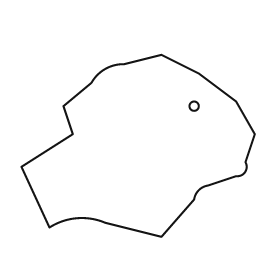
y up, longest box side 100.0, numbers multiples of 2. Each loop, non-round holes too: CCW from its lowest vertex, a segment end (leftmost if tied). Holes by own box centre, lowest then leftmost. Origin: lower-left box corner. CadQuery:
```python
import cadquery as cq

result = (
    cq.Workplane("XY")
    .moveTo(60.0, 0.0)
    .lineTo(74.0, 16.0)
    .threePointArc((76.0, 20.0), (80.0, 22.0))
    .lineTo(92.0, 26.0)
    .threePointArc((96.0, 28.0), (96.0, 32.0))
    .lineTo(100.0, 44.0)
    .lineTo(92.0, 58.0)
    .lineTo(76.0, 70.0)
    .lineTo(60.0, 78.0)
    .lineTo(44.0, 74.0)
    .threePointArc((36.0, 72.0), (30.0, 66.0))
    .lineTo(18.0, 56.0)
    .lineTo(22.0, 44.0)
    .lineTo(0.0, 30.0)
    .lineTo(12.0, 4.0)
    .threePointArc((24.0, 8.0), (36.0, 6.0))
    .close()
    .moveTo(74.0, 56.0)
    .circle(2.0)
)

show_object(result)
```